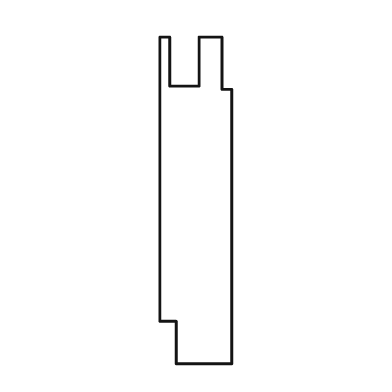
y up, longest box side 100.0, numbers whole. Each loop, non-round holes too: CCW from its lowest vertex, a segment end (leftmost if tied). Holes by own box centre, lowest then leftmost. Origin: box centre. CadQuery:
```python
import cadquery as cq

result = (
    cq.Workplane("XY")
    .moveTo(-6.0, -50.0)
    .lineTo(11.0, -50.0)
    .lineTo(11.0, 34.0)
    .lineTo(8.0, 34.0)
    .lineTo(8.0, 50.0)
    .lineTo(1.0, 50.0)
    .lineTo(1.0, 35.0)
    .lineTo(-8.0, 35.0)
    .lineTo(-8.0, 50.0)
    .lineTo(-11.0, 50.0)
    .lineTo(-11.0, -37.0)
    .lineTo(-6.0, -37.0)
    .close()
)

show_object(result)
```